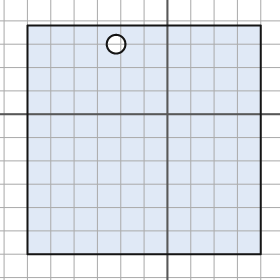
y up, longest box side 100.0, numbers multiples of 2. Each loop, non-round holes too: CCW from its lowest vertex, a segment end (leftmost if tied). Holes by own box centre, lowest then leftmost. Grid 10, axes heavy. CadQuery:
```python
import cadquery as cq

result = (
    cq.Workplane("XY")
    .moveTo(-60.0, -60.0)
    .lineTo(40.0, -60.0)
    .lineTo(40.0, 38.0)
    .lineTo(-60.0, 38.0)
    .close()
    .moveTo(-22.0, 30.0)
    .circle(4.0)
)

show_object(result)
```